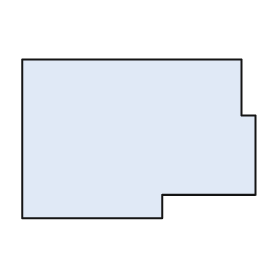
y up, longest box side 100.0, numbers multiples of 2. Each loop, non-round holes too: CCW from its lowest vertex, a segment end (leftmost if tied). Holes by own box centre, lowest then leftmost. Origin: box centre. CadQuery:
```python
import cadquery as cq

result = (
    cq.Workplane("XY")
    .moveTo(-50.0, -34.0)
    .lineTo(10.0, -34.0)
    .lineTo(10.0, -24.0)
    .lineTo(50.0, -24.0)
    .lineTo(50.0, 10.0)
    .lineTo(44.0, 10.0)
    .lineTo(44.0, 34.0)
    .lineTo(-50.0, 34.0)
    .close()
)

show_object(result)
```